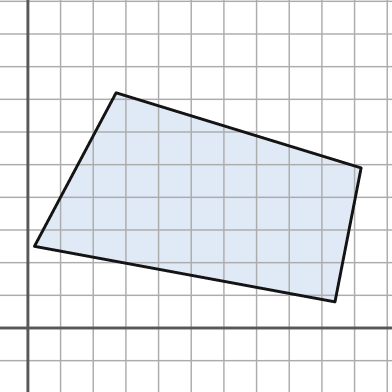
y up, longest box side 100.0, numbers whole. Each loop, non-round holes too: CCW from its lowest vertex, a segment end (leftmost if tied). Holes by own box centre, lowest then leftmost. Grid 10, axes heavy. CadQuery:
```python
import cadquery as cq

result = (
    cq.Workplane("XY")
    .moveTo(94.0, 8.0)
    .lineTo(102.0, 49.0)
    .lineTo(27.0, 72.0)
    .lineTo(2.0, 25.0)
    .close()
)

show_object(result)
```